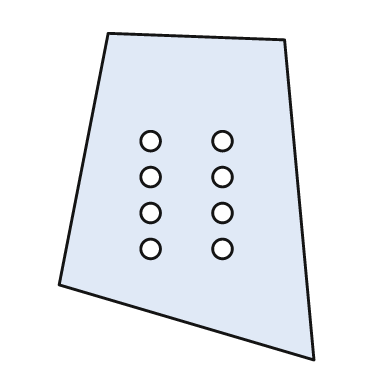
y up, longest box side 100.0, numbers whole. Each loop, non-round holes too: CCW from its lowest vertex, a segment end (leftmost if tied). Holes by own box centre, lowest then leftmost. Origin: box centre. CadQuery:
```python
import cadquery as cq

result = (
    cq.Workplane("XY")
    .moveTo(39.0, -50.0)
    .lineTo(30.0, 48.0)
    .lineTo(-24.0, 50.0)
    .lineTo(-39.0, -27.0)
    .close()
    .moveTo(-11.0, -16.0)
    .circle(3.0)
    .moveTo(11.0, -16.0)
    .circle(3.0)
    .moveTo(-11.0, -5.0)
    .circle(3.0)
    .moveTo(11.0, -5.0)
    .circle(3.0)
    .moveTo(-11.0, 6.0)
    .circle(3.0)
    .moveTo(11.0, 6.0)
    .circle(3.0)
    .moveTo(-11.0, 17.0)
    .circle(3.0)
    .moveTo(11.0, 17.0)
    .circle(3.0)
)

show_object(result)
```